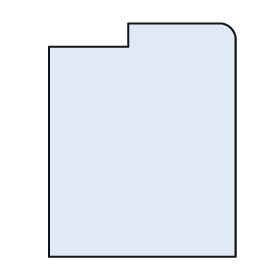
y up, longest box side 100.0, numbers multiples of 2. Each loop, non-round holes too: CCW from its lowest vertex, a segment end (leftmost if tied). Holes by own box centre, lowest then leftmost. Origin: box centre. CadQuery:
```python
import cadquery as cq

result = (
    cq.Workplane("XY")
    .moveTo(-40.0, -50.0)
    .lineTo(40.0, -50.0)
    .lineTo(40.0, 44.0)
    .threePointArc((38.0, 48.0), (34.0, 50.0))
    .lineTo(-6.0, 50.0)
    .lineTo(-6.0, 40.0)
    .lineTo(-40.0, 40.0)
    .close()
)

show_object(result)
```